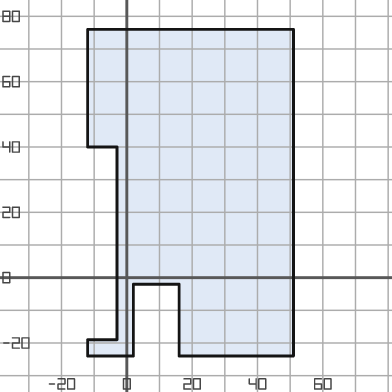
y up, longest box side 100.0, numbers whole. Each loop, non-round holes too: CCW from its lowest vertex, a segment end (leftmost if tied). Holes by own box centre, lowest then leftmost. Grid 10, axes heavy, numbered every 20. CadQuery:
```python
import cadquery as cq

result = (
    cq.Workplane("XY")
    .moveTo(-12.0, -24.0)
    .lineTo(2.0, -24.0)
    .lineTo(2.0, -2.0)
    .lineTo(16.0, -2.0)
    .lineTo(16.0, -24.0)
    .lineTo(51.0, -24.0)
    .lineTo(51.0, 76.0)
    .lineTo(-12.0, 76.0)
    .lineTo(-12.0, 40.0)
    .lineTo(-3.0, 40.0)
    .lineTo(-3.0, -19.0)
    .lineTo(-12.0, -19.0)
    .close()
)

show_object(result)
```